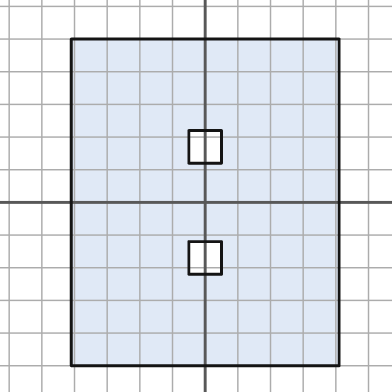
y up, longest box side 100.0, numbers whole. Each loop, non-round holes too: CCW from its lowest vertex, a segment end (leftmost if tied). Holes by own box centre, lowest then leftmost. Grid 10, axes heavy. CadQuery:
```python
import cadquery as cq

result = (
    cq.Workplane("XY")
    .moveTo(-41.0, -50.0)
    .lineTo(41.0, -50.0)
    .lineTo(41.0, 50.0)
    .lineTo(-41.0, 50.0)
    .close()
    .moveTo(-5.0, -22.0)
    .lineTo(5.0, -22.0)
    .lineTo(5.0, -12.0)
    .lineTo(-5.0, -12.0)
    .close()
    .moveTo(-5.0, 12.0)
    .lineTo(5.0, 12.0)
    .lineTo(5.0, 22.0)
    .lineTo(-5.0, 22.0)
    .close()
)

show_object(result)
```